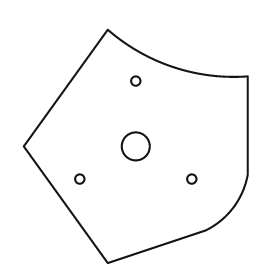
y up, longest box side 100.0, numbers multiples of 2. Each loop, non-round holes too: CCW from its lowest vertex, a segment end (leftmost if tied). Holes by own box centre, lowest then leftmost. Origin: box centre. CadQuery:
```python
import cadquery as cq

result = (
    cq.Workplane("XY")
    .moveTo(-12.0, -50.0)
    .lineTo(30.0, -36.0)
    .threePointArc((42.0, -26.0), (48.0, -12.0))
    .lineTo(48.0, 30.0)
    .threePointArc((16.0, 34.0), (-12.0, 50.0))
    .lineTo(-48.0, 0.0)
    .close()
    .moveTo(-24.0, -14.0)
    .circle(2.0)
    .moveTo(24.0, -14.0)
    .circle(2.0)
    .moveTo(0.0, 0.0)
    .circle(6.0)
    .moveTo(0.0, 28.0)
    .circle(2.0)
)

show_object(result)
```